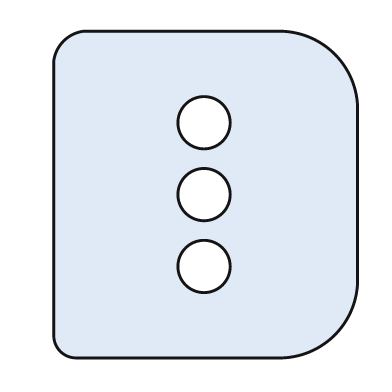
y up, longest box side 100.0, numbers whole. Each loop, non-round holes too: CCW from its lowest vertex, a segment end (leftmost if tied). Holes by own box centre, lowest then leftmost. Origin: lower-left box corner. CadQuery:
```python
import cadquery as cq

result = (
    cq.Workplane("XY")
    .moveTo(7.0, 0.0)
    .lineTo(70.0, 0.0)
    .threePointArc((86.0, 7.0), (93.0, 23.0))
    .lineTo(93.0, 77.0)
    .threePointArc((86.0, 93.0), (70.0, 100.0))
    .lineTo(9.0, 100.0)
    .threePointArc((3.0, 97.0), (0.0, 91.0))
    .lineTo(0.0, 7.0)
    .threePointArc((2.0, 2.0), (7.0, 0.0))
    .close()
    .moveTo(46.0, 28.0)
    .circle(8.0)
    .moveTo(46.0, 50.0)
    .circle(8.0)
    .moveTo(46.0, 72.0)
    .circle(8.0)
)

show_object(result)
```